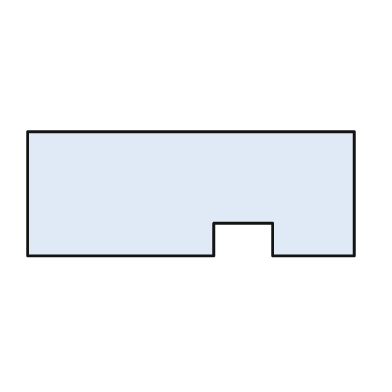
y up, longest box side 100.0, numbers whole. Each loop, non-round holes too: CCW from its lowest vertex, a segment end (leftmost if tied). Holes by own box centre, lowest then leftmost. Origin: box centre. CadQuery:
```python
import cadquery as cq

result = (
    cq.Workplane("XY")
    .moveTo(-50.0, -19.0)
    .lineTo(7.0, -19.0)
    .lineTo(7.0, -9.0)
    .lineTo(25.0, -9.0)
    .lineTo(25.0, -19.0)
    .lineTo(50.0, -19.0)
    .lineTo(50.0, 19.0)
    .lineTo(-50.0, 19.0)
    .close()
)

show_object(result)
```